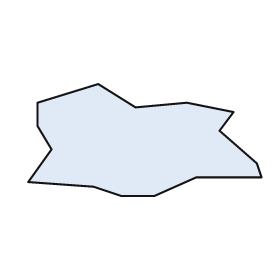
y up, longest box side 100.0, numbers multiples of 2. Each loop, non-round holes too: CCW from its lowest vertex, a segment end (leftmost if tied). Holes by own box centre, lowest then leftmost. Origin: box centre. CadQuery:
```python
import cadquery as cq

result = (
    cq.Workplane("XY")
    .moveTo(-10.0, -24.0)
    .lineTo(4.0, -24.0)
    .lineTo(22.0, -16.0)
    .lineTo(50.0, -16.0)
    .lineTo(48.0, -10.0)
    .lineTo(32.0, 4.0)
    .lineTo(38.0, 12.0)
    .lineTo(18.0, 16.0)
    .lineTo(-4.0, 14.0)
    .lineTo(-20.0, 24.0)
    .lineTo(-46.0, 16.0)
    .lineTo(-46.0, 6.0)
    .lineTo(-40.0, -4.0)
    .lineTo(-50.0, -18.0)
    .lineTo(-22.0, -20.0)
    .close()
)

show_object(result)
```